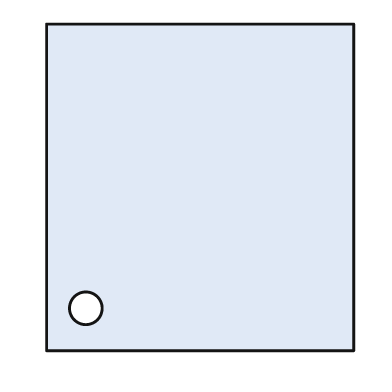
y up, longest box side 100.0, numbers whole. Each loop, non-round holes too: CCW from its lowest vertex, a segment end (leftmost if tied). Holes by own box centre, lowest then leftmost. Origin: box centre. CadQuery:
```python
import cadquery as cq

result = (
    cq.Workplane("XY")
    .moveTo(-47.0, -50.0)
    .lineTo(47.0, -50.0)
    .lineTo(47.0, 50.0)
    .lineTo(-47.0, 50.0)
    .close()
    .moveTo(-35.0, -37.0)
    .circle(5.0)
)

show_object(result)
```